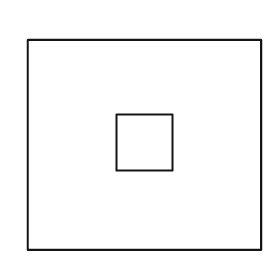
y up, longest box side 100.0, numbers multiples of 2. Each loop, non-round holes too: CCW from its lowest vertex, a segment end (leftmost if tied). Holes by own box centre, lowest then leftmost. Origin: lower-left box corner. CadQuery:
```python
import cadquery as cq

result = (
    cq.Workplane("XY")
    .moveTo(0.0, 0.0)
    .lineTo(100.0, 0.0)
    .lineTo(100.0, 90.0)
    .lineTo(0.0, 90.0)
    .close()
    .moveTo(38.0, 34.0)
    .lineTo(62.0, 34.0)
    .lineTo(62.0, 58.0)
    .lineTo(38.0, 58.0)
    .close()
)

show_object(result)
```